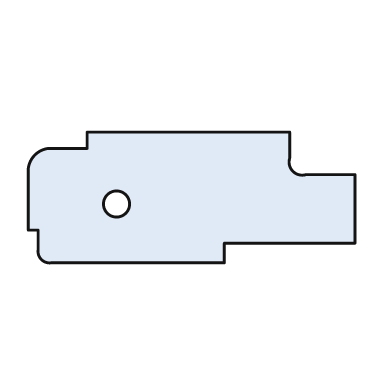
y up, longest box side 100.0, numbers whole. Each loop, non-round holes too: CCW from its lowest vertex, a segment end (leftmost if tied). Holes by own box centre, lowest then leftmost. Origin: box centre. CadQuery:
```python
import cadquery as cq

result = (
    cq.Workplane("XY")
    .moveTo(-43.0, -20.0)
    .lineTo(10.0, -20.0)
    .lineTo(10.0, -14.0)
    .lineTo(50.0, -14.0)
    .lineTo(50.0, 7.0)
    .lineTo(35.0, 7.0)
    .threePointArc((31.0, 8.0), (30.0, 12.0))
    .lineTo(30.0, 20.0)
    .lineTo(-32.0, 20.0)
    .lineTo(-32.0, 15.0)
    .lineTo(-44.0, 15.0)
    .threePointArc((-48.0, 13.0), (-50.0, 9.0))
    .lineTo(-50.0, -10.0)
    .lineTo(-47.0, -10.0)
    .lineTo(-47.0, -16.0)
    .threePointArc((-46.0, -19.0), (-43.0, -20.0))
    .close()
    .moveTo(-23.0, -2.0)
    .circle(4.0)
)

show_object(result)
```